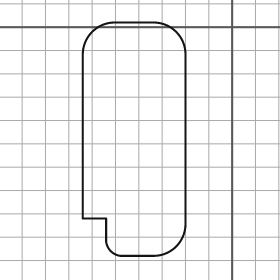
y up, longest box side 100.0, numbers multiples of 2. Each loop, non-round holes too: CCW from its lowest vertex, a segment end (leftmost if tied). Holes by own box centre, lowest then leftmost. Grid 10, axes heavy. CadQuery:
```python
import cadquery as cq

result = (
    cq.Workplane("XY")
    .moveTo(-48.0, -98.0)
    .lineTo(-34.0, -98.0)
    .threePointArc((-24.0, -94.0), (-20.0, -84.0))
    .lineTo(-20.0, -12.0)
    .threePointArc((-24.0, -2.0), (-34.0, 2.0))
    .lineTo(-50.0, 2.0)
    .threePointArc((-60.0, -2.0), (-64.0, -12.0))
    .lineTo(-64.0, -82.0)
    .lineTo(-54.0, -82.0)
    .lineTo(-54.0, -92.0)
    .threePointArc((-52.0, -96.0), (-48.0, -98.0))
    .close()
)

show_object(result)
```